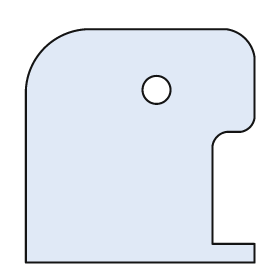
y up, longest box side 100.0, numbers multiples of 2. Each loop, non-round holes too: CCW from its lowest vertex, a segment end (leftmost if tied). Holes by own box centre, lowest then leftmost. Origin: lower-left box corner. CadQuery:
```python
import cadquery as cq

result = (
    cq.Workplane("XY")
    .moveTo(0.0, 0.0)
    .lineTo(98.0, 0.0)
    .lineTo(98.0, 8.0)
    .lineTo(80.0, 8.0)
    .lineTo(80.0, 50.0)
    .threePointArc((82.0, 54.0), (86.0, 56.0))
    .lineTo(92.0, 56.0)
    .threePointArc((96.0, 58.0), (98.0, 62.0))
    .lineTo(98.0, 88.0)
    .threePointArc((94.0, 96.0), (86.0, 100.0))
    .lineTo(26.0, 100.0)
    .threePointArc((8.0, 92.0), (0.0, 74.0))
    .close()
    .moveTo(56.0, 74.0)
    .circle(6.0)
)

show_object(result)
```